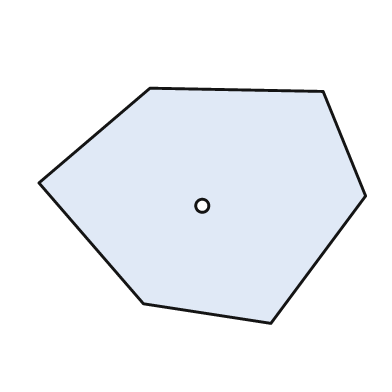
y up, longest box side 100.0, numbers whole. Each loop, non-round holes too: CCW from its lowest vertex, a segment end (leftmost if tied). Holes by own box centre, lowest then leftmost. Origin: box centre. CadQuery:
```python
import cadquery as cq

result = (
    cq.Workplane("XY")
    .moveTo(21.0, -36.0)
    .lineTo(50.0, 3.0)
    .lineTo(37.0, 35.0)
    .lineTo(-16.0, 36.0)
    .lineTo(-50.0, 7.0)
    .lineTo(-18.0, -30.0)
    .close()
    .moveTo(0.0, 0.0)
    .circle(2.0)
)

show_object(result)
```